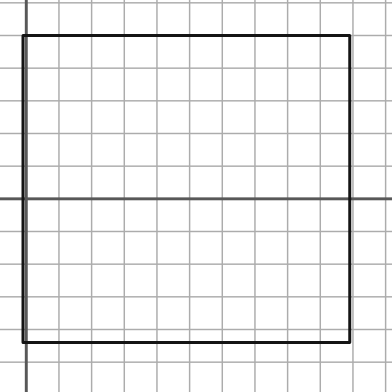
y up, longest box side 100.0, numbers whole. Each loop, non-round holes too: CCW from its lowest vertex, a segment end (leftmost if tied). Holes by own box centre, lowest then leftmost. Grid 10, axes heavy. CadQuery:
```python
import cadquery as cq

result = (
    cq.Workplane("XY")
    .moveTo(-1.0, -44.0)
    .lineTo(99.0, -44.0)
    .lineTo(99.0, 50.0)
    .lineTo(-1.0, 50.0)
    .close()
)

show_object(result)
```